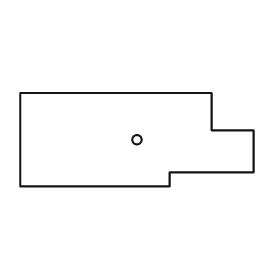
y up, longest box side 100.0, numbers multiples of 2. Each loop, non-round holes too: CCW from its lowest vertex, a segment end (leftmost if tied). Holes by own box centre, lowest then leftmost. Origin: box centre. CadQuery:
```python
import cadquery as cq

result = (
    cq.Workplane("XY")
    .moveTo(-50.0, -20.0)
    .lineTo(14.0, -20.0)
    .lineTo(14.0, -14.0)
    .lineTo(50.0, -14.0)
    .lineTo(50.0, 4.0)
    .lineTo(32.0, 4.0)
    .lineTo(32.0, 20.0)
    .lineTo(-50.0, 20.0)
    .close()
    .moveTo(0.0, 0.0)
    .circle(2.0)
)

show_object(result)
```